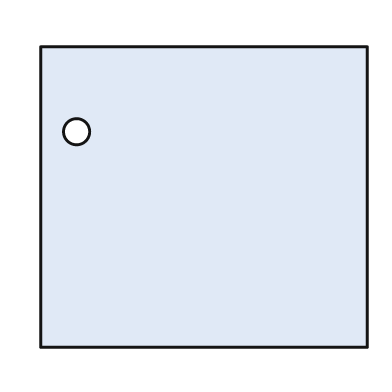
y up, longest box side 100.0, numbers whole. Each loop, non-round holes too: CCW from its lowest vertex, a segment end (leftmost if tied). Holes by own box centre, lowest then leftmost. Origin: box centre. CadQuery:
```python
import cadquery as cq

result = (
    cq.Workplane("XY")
    .moveTo(-50.0, -46.0)
    .lineTo(50.0, -46.0)
    .lineTo(50.0, 46.0)
    .lineTo(-50.0, 46.0)
    .close()
    .moveTo(-39.0, 20.0)
    .circle(4.0)
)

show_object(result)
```